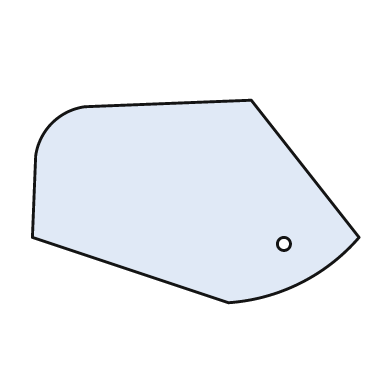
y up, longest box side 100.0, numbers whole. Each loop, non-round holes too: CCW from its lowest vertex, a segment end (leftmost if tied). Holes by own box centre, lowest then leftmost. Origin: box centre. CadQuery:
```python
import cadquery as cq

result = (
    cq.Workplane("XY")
    .moveTo(10.0, -31.0)
    .threePointArc((32.0, -25.0), (50.0, -11.0))
    .lineTo(17.0, 31.0)
    .lineTo(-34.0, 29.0)
    .threePointArc((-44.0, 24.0), (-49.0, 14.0))
    .lineTo(-50.0, -11.0)
    .close()
    .moveTo(27.0, -13.0)
    .circle(2.0)
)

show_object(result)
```